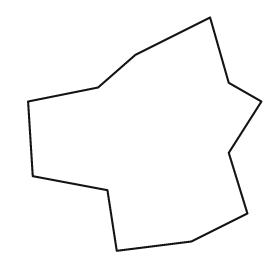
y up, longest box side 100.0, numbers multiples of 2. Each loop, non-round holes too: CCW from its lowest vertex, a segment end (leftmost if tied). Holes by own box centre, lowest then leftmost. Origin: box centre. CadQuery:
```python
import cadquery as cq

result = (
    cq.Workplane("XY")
    .moveTo(-12.0, -50.0)
    .lineTo(20.0, -46.0)
    .lineTo(44.0, -34.0)
    .lineTo(36.0, -8.0)
    .lineTo(50.0, 14.0)
    .lineTo(36.0, 22.0)
    .lineTo(28.0, 50.0)
    .lineTo(-4.0, 34.0)
    .lineTo(-20.0, 20.0)
    .lineTo(-50.0, 14.0)
    .lineTo(-48.0, -18.0)
    .lineTo(-16.0, -24.0)
    .close()
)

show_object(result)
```